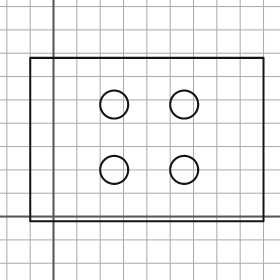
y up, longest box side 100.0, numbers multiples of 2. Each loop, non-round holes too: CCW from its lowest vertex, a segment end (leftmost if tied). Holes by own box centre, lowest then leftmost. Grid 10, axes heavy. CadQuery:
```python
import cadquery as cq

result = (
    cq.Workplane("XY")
    .moveTo(-10.0, -2.0)
    .lineTo(90.0, -2.0)
    .lineTo(90.0, 68.0)
    .lineTo(-10.0, 68.0)
    .close()
    .moveTo(26.0, 20.0)
    .circle(6.0)
    .moveTo(56.0, 20.0)
    .circle(6.0)
    .moveTo(26.0, 48.0)
    .circle(6.0)
    .moveTo(56.0, 48.0)
    .circle(6.0)
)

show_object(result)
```